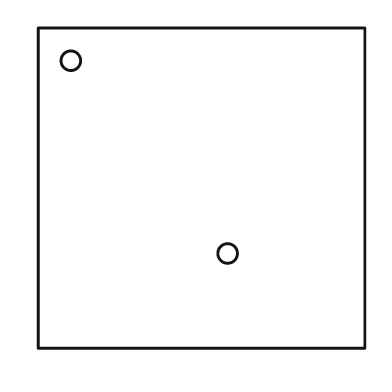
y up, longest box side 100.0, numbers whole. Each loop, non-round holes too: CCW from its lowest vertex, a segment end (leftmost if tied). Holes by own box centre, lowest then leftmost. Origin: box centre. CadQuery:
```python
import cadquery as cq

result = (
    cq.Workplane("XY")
    .moveTo(-50.0, -49.0)
    .lineTo(50.0, -49.0)
    .lineTo(50.0, 49.0)
    .lineTo(-50.0, 49.0)
    .close()
    .moveTo(8.0, -20.0)
    .circle(3.0)
    .moveTo(-40.0, 39.0)
    .circle(3.0)
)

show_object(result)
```